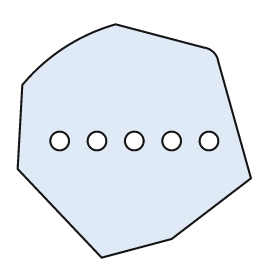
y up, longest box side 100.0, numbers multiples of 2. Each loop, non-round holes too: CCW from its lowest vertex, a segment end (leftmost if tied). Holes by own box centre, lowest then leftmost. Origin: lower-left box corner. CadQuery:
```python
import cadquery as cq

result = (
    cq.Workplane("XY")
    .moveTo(36.0, 0.0)
    .lineTo(66.0, 8.0)
    .lineTo(100.0, 34.0)
    .lineTo(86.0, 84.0)
    .threePointArc((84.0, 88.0), (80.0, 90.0))
    .lineTo(42.0, 100.0)
    .threePointArc((20.0, 90.0), (2.0, 74.0))
    .lineTo(0.0, 38.0)
    .close()
    .moveTo(18.0, 50.0)
    .circle(4.0)
    .moveTo(34.0, 50.0)
    .circle(4.0)
    .moveTo(50.0, 50.0)
    .circle(4.0)
    .moveTo(66.0, 50.0)
    .circle(4.0)
    .moveTo(82.0, 50.0)
    .circle(4.0)
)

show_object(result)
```